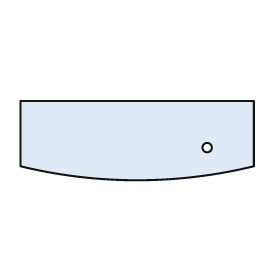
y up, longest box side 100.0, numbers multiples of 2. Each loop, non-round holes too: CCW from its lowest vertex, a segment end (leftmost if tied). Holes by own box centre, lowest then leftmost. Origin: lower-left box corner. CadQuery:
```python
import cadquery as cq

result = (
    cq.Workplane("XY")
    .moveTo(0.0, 6.0)
    .threePointArc((50.0, 0.0), (100.0, 6.0))
    .lineTo(100.0, 34.0)
    .lineTo(0.0, 34.0)
    .close()
    .moveTo(80.0, 14.0)
    .circle(2.0)
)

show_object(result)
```